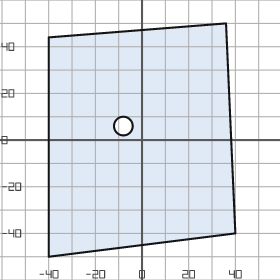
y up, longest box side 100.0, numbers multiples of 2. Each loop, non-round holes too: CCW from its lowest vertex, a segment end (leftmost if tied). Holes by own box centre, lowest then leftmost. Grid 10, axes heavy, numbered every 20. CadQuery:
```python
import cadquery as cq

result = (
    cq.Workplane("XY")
    .moveTo(-40.0, -50.0)
    .lineTo(40.0, -40.0)
    .lineTo(36.0, 50.0)
    .lineTo(-40.0, 44.0)
    .close()
    .moveTo(-8.0, 6.0)
    .circle(4.0)
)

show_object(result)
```